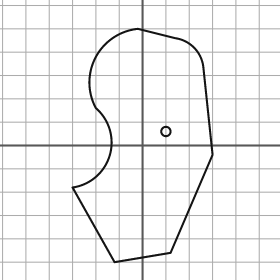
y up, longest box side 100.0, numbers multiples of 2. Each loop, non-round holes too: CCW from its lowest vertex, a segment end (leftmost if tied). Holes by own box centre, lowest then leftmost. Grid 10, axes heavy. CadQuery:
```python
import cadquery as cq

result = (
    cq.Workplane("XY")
    .moveTo(-12.0, -50.0)
    .lineTo(12.0, -46.0)
    .lineTo(30.0, -4.0)
    .lineTo(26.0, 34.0)
    .threePointArc((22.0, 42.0), (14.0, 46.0))
    .lineTo(-2.0, 50.0)
    .threePointArc((-20.0, 38.0), (-20.0, 16.0))
    .threePointArc((-14.0, -4.0), (-30.0, -18.0))
    .close()
    .moveTo(10.0, 6.0)
    .circle(2.0)
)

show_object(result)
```